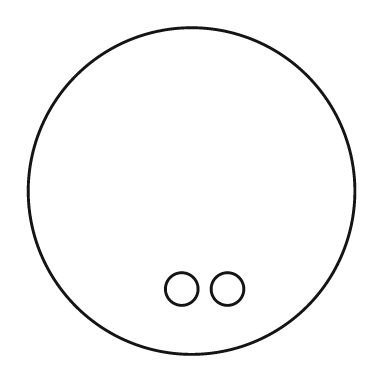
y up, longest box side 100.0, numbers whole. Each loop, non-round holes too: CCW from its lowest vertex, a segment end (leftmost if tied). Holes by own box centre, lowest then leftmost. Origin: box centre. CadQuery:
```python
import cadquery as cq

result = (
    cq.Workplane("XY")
    .moveTo(0.0, 0.0)
    .circle(50.0)
    .moveTo(-3.0, -30.0)
    .circle(5.0)
    .moveTo(11.0, -30.0)
    .circle(5.0)
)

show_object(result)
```